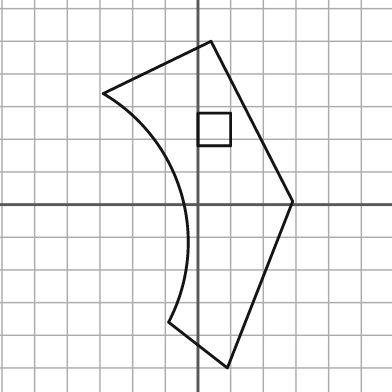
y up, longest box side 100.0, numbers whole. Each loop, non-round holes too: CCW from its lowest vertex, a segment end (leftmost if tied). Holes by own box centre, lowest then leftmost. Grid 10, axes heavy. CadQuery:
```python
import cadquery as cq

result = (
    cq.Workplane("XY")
    .moveTo(9.0, -50.0)
    .lineTo(29.0, 1.0)
    .lineTo(4.0, 50.0)
    .lineTo(-29.0, 34.0)
    .threePointArc((-5.0, 3.0), (-9.0, -36.0))
    .close()
    .moveTo(0.0, 18.0)
    .lineTo(10.0, 18.0)
    .lineTo(10.0, 28.0)
    .lineTo(0.0, 28.0)
    .close()
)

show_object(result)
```